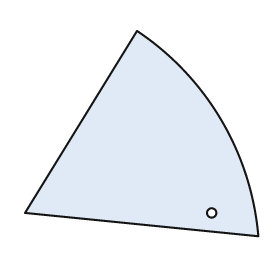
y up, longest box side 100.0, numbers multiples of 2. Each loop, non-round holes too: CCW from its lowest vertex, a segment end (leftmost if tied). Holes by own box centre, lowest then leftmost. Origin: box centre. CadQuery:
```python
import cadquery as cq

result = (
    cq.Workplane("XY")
    .moveTo(50.0, -44.0)
    .threePointArc((34.0, 6.0), (-2.0, 44.0))
    .lineTo(-50.0, -34.0)
    .close()
    .moveTo(30.0, -34.0)
    .circle(2.0)
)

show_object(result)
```